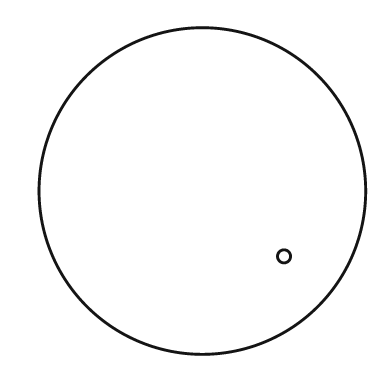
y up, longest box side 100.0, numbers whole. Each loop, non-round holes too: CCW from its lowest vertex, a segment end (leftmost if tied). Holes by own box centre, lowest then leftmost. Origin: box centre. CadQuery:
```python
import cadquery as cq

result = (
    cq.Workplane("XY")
    .moveTo(0.0, 0.0)
    .circle(50.0)
    .moveTo(25.0, -20.0)
    .circle(2.0)
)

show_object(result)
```